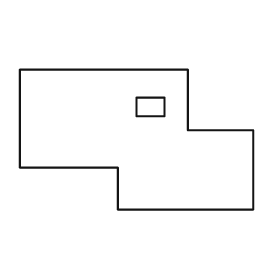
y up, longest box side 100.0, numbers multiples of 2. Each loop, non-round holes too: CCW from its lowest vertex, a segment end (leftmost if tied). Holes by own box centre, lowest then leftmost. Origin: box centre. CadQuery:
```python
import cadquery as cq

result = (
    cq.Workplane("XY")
    .moveTo(-8.0, -30.0)
    .lineTo(50.0, -30.0)
    .lineTo(50.0, 4.0)
    .lineTo(22.0, 4.0)
    .lineTo(22.0, 30.0)
    .lineTo(-50.0, 30.0)
    .lineTo(-50.0, -12.0)
    .lineTo(-8.0, -12.0)
    .close()
    .moveTo(0.0, 10.0)
    .lineTo(12.0, 10.0)
    .lineTo(12.0, 18.0)
    .lineTo(0.0, 18.0)
    .close()
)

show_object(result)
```